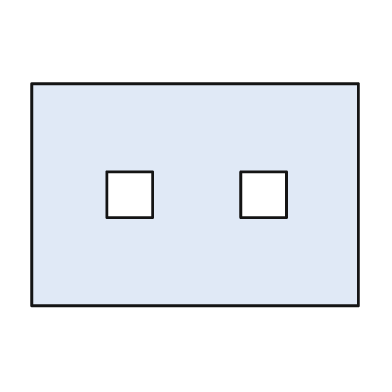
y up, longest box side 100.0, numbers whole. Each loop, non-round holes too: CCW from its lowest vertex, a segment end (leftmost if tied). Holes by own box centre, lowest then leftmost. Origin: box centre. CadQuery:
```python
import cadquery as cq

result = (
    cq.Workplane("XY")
    .moveTo(-50.0, -34.0)
    .lineTo(50.0, -34.0)
    .lineTo(50.0, 34.0)
    .lineTo(-50.0, 34.0)
    .close()
    .moveTo(-27.0, -7.0)
    .lineTo(-13.0, -7.0)
    .lineTo(-13.0, 7.0)
    .lineTo(-27.0, 7.0)
    .close()
    .moveTo(14.0, -7.0)
    .lineTo(28.0, -7.0)
    .lineTo(28.0, 7.0)
    .lineTo(14.0, 7.0)
    .close()
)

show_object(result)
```